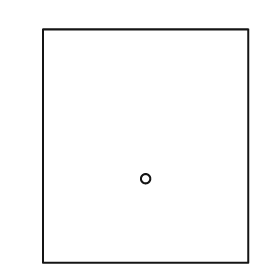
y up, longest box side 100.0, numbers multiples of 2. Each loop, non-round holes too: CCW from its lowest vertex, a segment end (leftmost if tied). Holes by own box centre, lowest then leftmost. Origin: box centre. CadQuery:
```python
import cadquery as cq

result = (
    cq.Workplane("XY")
    .moveTo(-44.0, -50.0)
    .lineTo(44.0, -50.0)
    .lineTo(44.0, 50.0)
    .lineTo(-44.0, 50.0)
    .close()
    .moveTo(0.0, -14.0)
    .circle(2.0)
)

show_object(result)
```